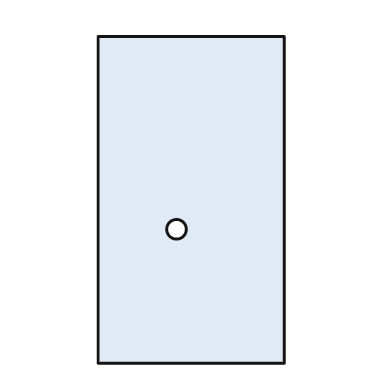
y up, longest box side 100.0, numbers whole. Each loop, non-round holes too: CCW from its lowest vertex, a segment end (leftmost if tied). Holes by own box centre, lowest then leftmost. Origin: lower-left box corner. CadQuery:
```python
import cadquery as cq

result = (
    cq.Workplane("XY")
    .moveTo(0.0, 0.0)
    .lineTo(57.0, 0.0)
    .lineTo(57.0, 100.0)
    .lineTo(0.0, 100.0)
    .close()
    .moveTo(24.0, 41.0)
    .circle(3.0)
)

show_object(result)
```